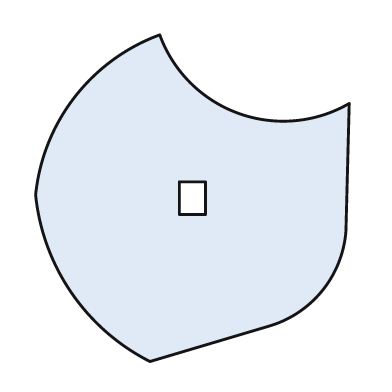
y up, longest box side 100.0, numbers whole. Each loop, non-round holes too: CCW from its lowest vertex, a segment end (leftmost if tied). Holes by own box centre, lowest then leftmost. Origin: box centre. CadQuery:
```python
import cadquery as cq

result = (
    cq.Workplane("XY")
    .moveTo(-13.0, -50.0)
    .lineTo(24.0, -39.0)
    .threePointArc((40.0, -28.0), (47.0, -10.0))
    .lineTo(48.0, 29.0)
    .threePointArc((14.0, 26.0), (-10.0, 50.0))
    .threePointArc((-36.0, 31.0), (-48.0, 1.0))
    .threePointArc((-37.0, -29.0), (-13.0, -50.0))
    .close()
    .moveTo(-4.0, -5.0)
    .lineTo(4.0, -5.0)
    .lineTo(4.0, 5.0)
    .lineTo(-4.0, 5.0)
    .close()
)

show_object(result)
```